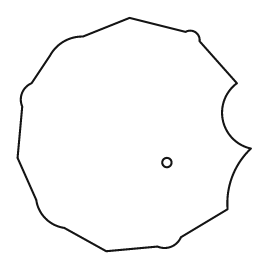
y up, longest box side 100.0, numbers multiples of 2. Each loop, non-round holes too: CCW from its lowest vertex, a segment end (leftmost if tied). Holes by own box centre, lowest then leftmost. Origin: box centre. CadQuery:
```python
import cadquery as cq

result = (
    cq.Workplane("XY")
    .moveTo(-12.0, -50.0)
    .lineTo(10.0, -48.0)
    .threePointArc((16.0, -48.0), (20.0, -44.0))
    .lineTo(40.0, -32.0)
    .threePointArc((42.0, -18.0), (50.0, -6.0))
    .threePointArc((38.0, 6.0), (44.0, 22.0))
    .lineTo(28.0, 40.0)
    .threePointArc((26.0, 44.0), (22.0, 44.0))
    .lineTo(-2.0, 50.0)
    .lineTo(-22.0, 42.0)
    .threePointArc((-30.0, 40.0), (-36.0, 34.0))
    .lineTo(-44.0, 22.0)
    .threePointArc((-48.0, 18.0), (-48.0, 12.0))
    .lineTo(-50.0, -10.0)
    .lineTo(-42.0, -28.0)
    .threePointArc((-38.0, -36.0), (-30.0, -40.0))
    .close()
    .moveTo(14.0, -12.0)
    .circle(2.0)
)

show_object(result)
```